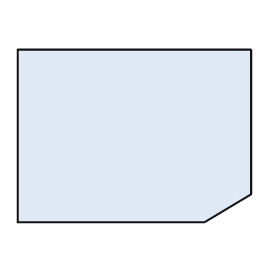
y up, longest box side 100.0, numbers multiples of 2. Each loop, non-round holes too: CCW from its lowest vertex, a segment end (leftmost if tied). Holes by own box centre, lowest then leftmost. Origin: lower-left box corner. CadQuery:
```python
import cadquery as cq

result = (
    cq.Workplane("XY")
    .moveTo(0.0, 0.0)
    .lineTo(80.0, 0.0)
    .lineTo(100.0, 12.0)
    .lineTo(100.0, 74.0)
    .lineTo(0.0, 74.0)
    .close()
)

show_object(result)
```